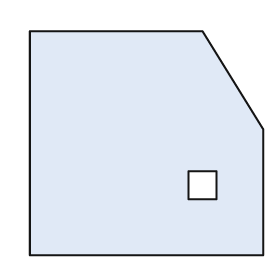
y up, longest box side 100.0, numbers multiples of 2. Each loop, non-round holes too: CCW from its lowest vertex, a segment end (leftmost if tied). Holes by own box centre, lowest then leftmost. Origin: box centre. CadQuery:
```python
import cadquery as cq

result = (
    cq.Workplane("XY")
    .moveTo(-50.0, -48.0)
    .lineTo(50.0, -48.0)
    .lineTo(50.0, 6.0)
    .lineTo(24.0, 48.0)
    .lineTo(-50.0, 48.0)
    .close()
    .moveTo(18.0, -24.0)
    .lineTo(30.0, -24.0)
    .lineTo(30.0, -12.0)
    .lineTo(18.0, -12.0)
    .close()
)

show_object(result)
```